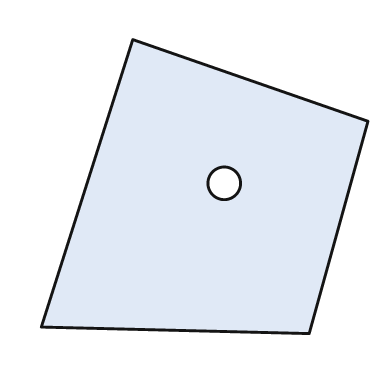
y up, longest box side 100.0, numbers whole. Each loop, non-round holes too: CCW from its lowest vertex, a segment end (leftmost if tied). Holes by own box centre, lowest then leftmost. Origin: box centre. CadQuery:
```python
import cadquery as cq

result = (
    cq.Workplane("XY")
    .moveTo(32.0, -45.0)
    .lineTo(50.0, 20.0)
    .lineTo(-22.0, 45.0)
    .lineTo(-50.0, -43.0)
    .close()
    .moveTo(6.0, 1.0)
    .circle(5.0)
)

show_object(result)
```